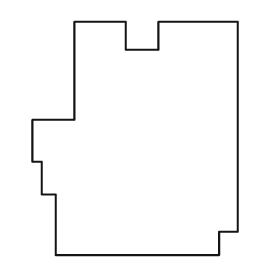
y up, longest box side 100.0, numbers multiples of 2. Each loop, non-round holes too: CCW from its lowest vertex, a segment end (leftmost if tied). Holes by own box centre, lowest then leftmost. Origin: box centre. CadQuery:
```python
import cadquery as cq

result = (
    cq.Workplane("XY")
    .moveTo(-34.0, -50.0)
    .lineTo(36.0, -50.0)
    .lineTo(36.0, -40.0)
    .lineTo(44.0, -40.0)
    .lineTo(44.0, 50.0)
    .lineTo(10.0, 50.0)
    .lineTo(10.0, 38.0)
    .lineTo(-4.0, 38.0)
    .lineTo(-4.0, 50.0)
    .lineTo(-26.0, 50.0)
    .lineTo(-26.0, 8.0)
    .lineTo(-44.0, 8.0)
    .lineTo(-44.0, -10.0)
    .lineTo(-40.0, -10.0)
    .lineTo(-40.0, -24.0)
    .lineTo(-34.0, -24.0)
    .close()
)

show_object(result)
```